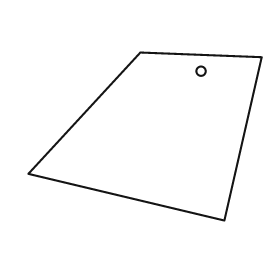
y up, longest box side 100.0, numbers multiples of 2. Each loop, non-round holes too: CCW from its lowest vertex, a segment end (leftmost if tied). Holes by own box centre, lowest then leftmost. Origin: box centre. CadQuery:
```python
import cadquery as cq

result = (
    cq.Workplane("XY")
    .moveTo(34.0, -36.0)
    .lineTo(50.0, 34.0)
    .lineTo(-2.0, 36.0)
    .lineTo(-50.0, -16.0)
    .close()
    .moveTo(24.0, 28.0)
    .circle(2.0)
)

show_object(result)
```